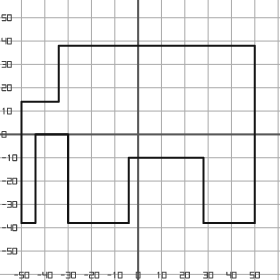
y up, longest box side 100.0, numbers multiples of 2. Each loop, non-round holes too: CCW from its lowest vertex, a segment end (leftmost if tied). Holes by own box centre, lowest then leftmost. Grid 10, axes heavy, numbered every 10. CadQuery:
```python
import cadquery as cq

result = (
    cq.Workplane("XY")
    .moveTo(-50.0, -38.0)
    .lineTo(-44.0, -38.0)
    .lineTo(-44.0, 0.0)
    .lineTo(-30.0, 0.0)
    .lineTo(-30.0, -38.0)
    .lineTo(-4.0, -38.0)
    .lineTo(-4.0, -10.0)
    .lineTo(28.0, -10.0)
    .lineTo(28.0, -38.0)
    .lineTo(50.0, -38.0)
    .lineTo(50.0, 38.0)
    .lineTo(-34.0, 38.0)
    .lineTo(-34.0, 14.0)
    .lineTo(-50.0, 14.0)
    .close()
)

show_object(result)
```